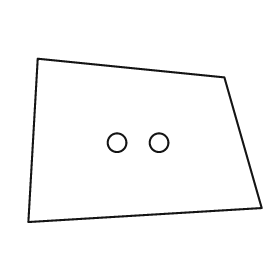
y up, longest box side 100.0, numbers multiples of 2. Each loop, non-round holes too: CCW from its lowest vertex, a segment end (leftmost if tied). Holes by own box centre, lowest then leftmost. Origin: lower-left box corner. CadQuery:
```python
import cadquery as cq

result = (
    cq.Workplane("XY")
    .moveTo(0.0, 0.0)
    .lineTo(100.0, 6.0)
    .lineTo(84.0, 62.0)
    .lineTo(4.0, 70.0)
    .close()
    .moveTo(38.0, 34.0)
    .circle(4.0)
    .moveTo(56.0, 34.0)
    .circle(4.0)
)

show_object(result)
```